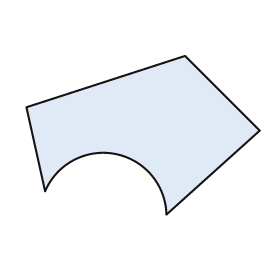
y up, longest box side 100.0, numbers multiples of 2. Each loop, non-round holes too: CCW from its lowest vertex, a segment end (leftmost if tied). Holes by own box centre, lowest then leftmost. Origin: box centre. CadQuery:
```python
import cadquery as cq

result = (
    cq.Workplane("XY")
    .moveTo(10.0, -34.0)
    .lineTo(50.0, 2.0)
    .lineTo(18.0, 34.0)
    .lineTo(-50.0, 12.0)
    .lineTo(-42.0, -24.0)
    .threePointArc((-12.0, -8.0), (10.0, -34.0))
    .close()
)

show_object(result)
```